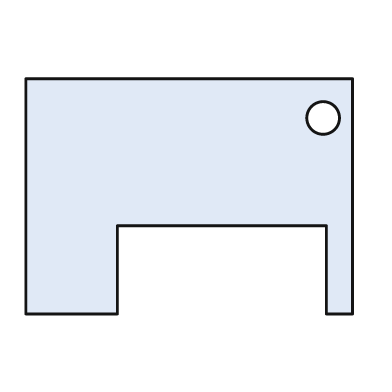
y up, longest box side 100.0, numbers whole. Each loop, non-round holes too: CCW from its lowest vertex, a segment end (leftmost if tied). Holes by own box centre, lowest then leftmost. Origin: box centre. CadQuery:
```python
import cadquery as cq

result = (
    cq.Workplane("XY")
    .moveTo(-50.0, -36.0)
    .lineTo(-22.0, -36.0)
    .lineTo(-22.0, -9.0)
    .lineTo(42.0, -9.0)
    .lineTo(42.0, -36.0)
    .lineTo(50.0, -36.0)
    .lineTo(50.0, 36.0)
    .lineTo(-50.0, 36.0)
    .close()
    .moveTo(41.0, 24.0)
    .circle(5.0)
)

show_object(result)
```